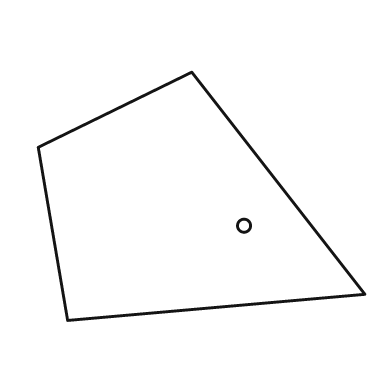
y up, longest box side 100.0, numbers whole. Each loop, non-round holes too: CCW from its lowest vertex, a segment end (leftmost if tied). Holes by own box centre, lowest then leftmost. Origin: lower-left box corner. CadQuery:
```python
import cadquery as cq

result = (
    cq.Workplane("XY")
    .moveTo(9.0, 0.0)
    .lineTo(100.0, 8.0)
    .lineTo(47.0, 76.0)
    .lineTo(0.0, 53.0)
    .close()
    .moveTo(63.0, 29.0)
    .circle(2.0)
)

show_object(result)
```